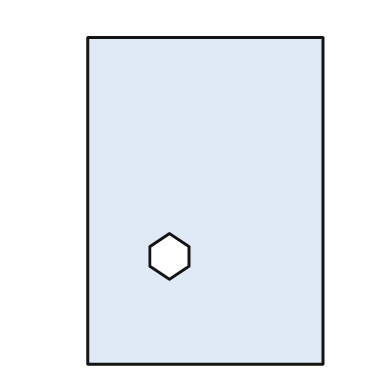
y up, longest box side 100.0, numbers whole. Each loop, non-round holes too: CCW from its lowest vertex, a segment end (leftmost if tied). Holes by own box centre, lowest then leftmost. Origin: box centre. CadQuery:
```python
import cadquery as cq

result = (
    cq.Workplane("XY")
    .moveTo(-36.0, -50.0)
    .lineTo(36.0, -50.0)
    .lineTo(36.0, 50.0)
    .lineTo(-36.0, 50.0)
    .close()
    .moveTo(-11.0, -24.0)
    .lineTo(-5.0, -20.0)
    .lineTo(-5.0, -14.0)
    .lineTo(-11.0, -10.0)
    .lineTo(-17.0, -14.0)
    .lineTo(-17.0, -20.0)
    .close()
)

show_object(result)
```